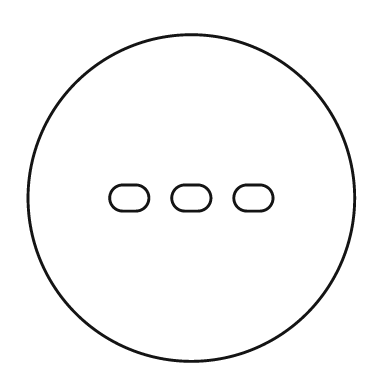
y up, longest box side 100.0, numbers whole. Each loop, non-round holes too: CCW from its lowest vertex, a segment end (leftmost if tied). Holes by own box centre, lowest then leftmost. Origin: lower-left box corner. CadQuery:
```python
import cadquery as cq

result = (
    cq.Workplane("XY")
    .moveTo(50.0, 50.0)
    .circle(50.0)
    .moveTo(29.0, 46.0)
    .lineTo(33.0, 46.0)
    .threePointArc((37.0, 50.0), (33.0, 54.0))
    .lineTo(29.0, 54.0)
    .threePointArc((25.0, 50.0), (29.0, 46.0))
    .close()
    .moveTo(48.0, 46.0)
    .lineTo(52.0, 46.0)
    .threePointArc((56.0, 50.0), (52.0, 54.0))
    .lineTo(48.0, 54.0)
    .threePointArc((44.0, 50.0), (48.0, 46.0))
    .close()
    .moveTo(67.0, 46.0)
    .lineTo(71.0, 46.0)
    .threePointArc((75.0, 50.0), (71.0, 54.0))
    .lineTo(67.0, 54.0)
    .threePointArc((63.0, 50.0), (67.0, 46.0))
    .close()
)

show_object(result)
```